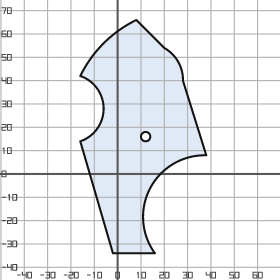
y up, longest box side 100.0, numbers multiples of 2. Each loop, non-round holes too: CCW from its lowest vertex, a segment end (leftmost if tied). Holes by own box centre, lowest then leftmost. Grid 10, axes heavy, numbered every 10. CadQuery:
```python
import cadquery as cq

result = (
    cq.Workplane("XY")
    .moveTo(-2.0, -34.0)
    .lineTo(16.0, -34.0)
    .threePointArc((14.0, -6.0), (38.0, 8.0))
    .lineTo(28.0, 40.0)
    .threePointArc((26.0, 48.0), (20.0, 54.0))
    .lineTo(8.0, 66.0)
    .threePointArc((-6.0, 56.0), (-16.0, 42.0))
    .threePointArc((-6.0, 28.0), (-16.0, 14.0))
    .close()
    .moveTo(12.0, 16.0)
    .circle(2.0)
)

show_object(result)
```